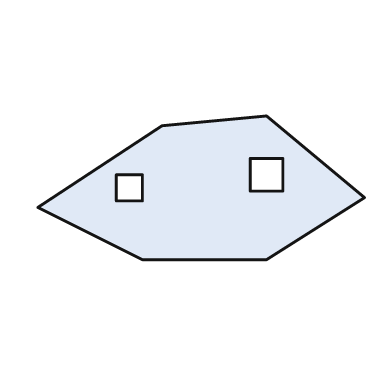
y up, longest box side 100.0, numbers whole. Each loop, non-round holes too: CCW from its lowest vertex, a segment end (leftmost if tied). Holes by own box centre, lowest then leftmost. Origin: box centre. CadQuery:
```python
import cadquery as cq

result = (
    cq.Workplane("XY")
    .moveTo(-18.0, -22.0)
    .lineTo(20.0, -22.0)
    .lineTo(50.0, -3.0)
    .lineTo(20.0, 22.0)
    .lineTo(-12.0, 19.0)
    .lineTo(-50.0, -6.0)
    .close()
    .moveTo(-26.0, -4.0)
    .lineTo(-18.0, -4.0)
    .lineTo(-18.0, 4.0)
    .lineTo(-26.0, 4.0)
    .close()
    .moveTo(15.0, -1.0)
    .lineTo(25.0, -1.0)
    .lineTo(25.0, 9.0)
    .lineTo(15.0, 9.0)
    .close()
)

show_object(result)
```